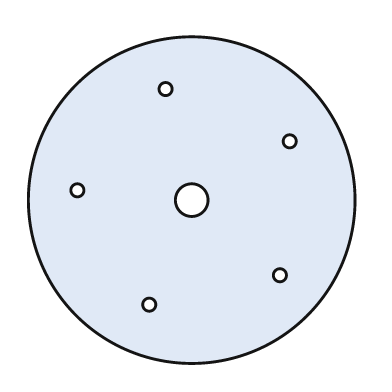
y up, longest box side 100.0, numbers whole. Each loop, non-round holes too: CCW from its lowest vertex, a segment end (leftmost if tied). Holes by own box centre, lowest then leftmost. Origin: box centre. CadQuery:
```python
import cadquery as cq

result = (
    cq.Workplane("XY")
    .moveTo(0.0, 0.0)
    .circle(50.0)
    .moveTo(-13.0, -32.0)
    .circle(2.0)
    .moveTo(27.0, -23.0)
    .circle(2.0)
    .moveTo(0.0, 0.0)
    .circle(5.0)
    .moveTo(-35.0, 3.0)
    .circle(2.0)
    .moveTo(30.0, 18.0)
    .circle(2.0)
    .moveTo(-8.0, 34.0)
    .circle(2.0)
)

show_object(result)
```